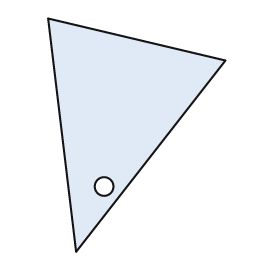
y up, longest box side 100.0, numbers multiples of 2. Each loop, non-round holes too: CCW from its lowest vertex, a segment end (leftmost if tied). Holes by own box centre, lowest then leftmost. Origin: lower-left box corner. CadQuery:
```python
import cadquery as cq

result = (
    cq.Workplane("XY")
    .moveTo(12.0, 0.0)
    .lineTo(76.0, 82.0)
    .lineTo(0.0, 100.0)
    .close()
    .moveTo(24.0, 28.0)
    .circle(4.0)
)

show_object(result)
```